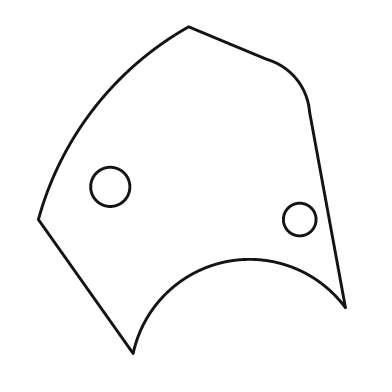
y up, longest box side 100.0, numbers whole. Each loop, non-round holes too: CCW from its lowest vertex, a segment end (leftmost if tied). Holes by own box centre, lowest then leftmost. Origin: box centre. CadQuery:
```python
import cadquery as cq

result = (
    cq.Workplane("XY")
    .moveTo(-18.0, -50.0)
    .threePointArc((10.0, -22.0), (47.0, -36.0))
    .lineTo(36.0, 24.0)
    .threePointArc((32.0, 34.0), (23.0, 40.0))
    .lineTo(-1.0, 50.0)
    .threePointArc((-30.0, 25.0), (-47.0, -9.0))
    .close()
    .moveTo(33.0, -9.0)
    .circle(5.0)
    .moveTo(-25.0, 1.0)
    .circle(6.0)
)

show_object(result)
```